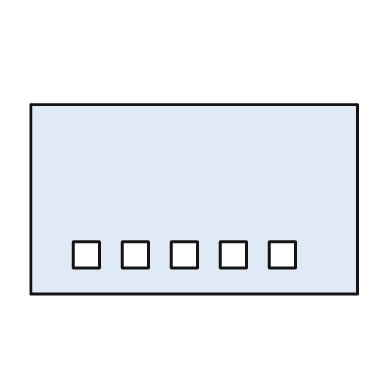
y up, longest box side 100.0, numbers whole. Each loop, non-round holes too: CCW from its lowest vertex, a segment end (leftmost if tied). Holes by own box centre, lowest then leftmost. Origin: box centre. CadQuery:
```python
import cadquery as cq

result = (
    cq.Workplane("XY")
    .moveTo(-50.0, -29.0)
    .lineTo(50.0, -29.0)
    .lineTo(50.0, 29.0)
    .lineTo(-50.0, 29.0)
    .close()
    .moveTo(-37.0, -21.0)
    .lineTo(-29.0, -21.0)
    .lineTo(-29.0, -13.0)
    .lineTo(-37.0, -13.0)
    .close()
    .moveTo(-22.0, -21.0)
    .lineTo(-14.0, -21.0)
    .lineTo(-14.0, -13.0)
    .lineTo(-22.0, -13.0)
    .close()
    .moveTo(-7.0, -21.0)
    .lineTo(1.0, -21.0)
    .lineTo(1.0, -13.0)
    .lineTo(-7.0, -13.0)
    .close()
    .moveTo(8.0, -21.0)
    .lineTo(16.0, -21.0)
    .lineTo(16.0, -13.0)
    .lineTo(8.0, -13.0)
    .close()
    .moveTo(23.0, -21.0)
    .lineTo(31.0, -21.0)
    .lineTo(31.0, -13.0)
    .lineTo(23.0, -13.0)
    .close()
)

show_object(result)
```